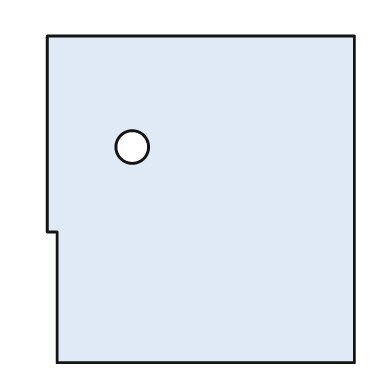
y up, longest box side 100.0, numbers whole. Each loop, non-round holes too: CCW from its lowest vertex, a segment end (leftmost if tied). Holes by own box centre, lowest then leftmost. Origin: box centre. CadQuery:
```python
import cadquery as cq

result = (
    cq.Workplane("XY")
    .moveTo(-44.0, -50.0)
    .lineTo(47.0, -50.0)
    .lineTo(47.0, 50.0)
    .lineTo(-47.0, 50.0)
    .lineTo(-47.0, -10.0)
    .lineTo(-44.0, -10.0)
    .close()
    .moveTo(-21.0, 16.0)
    .circle(5.0)
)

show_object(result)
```